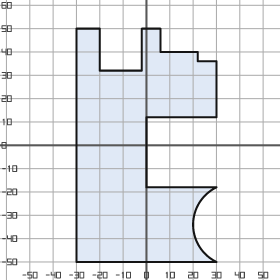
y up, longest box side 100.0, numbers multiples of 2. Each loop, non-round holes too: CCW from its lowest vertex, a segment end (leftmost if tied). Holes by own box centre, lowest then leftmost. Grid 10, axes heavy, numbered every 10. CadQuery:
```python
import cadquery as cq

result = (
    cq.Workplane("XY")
    .moveTo(-30.0, -50.0)
    .lineTo(30.0, -50.0)
    .threePointArc((20.0, -34.0), (30.0, -18.0))
    .lineTo(0.0, -18.0)
    .lineTo(0.0, 12.0)
    .lineTo(30.0, 12.0)
    .lineTo(30.0, 36.0)
    .lineTo(22.0, 36.0)
    .lineTo(22.0, 40.0)
    .lineTo(6.0, 40.0)
    .lineTo(6.0, 50.0)
    .lineTo(-2.0, 50.0)
    .lineTo(-2.0, 32.0)
    .lineTo(-20.0, 32.0)
    .lineTo(-20.0, 50.0)
    .lineTo(-30.0, 50.0)
    .close()
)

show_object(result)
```